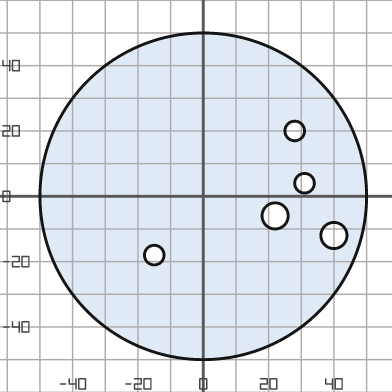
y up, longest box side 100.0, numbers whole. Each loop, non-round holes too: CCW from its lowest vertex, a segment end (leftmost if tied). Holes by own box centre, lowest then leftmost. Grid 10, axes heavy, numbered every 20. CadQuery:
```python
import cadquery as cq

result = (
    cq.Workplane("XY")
    .moveTo(0.0, 0.0)
    .circle(50.0)
    .moveTo(-15.0, -18.0)
    .circle(3.0)
    .moveTo(40.0, -12.0)
    .circle(4.0)
    .moveTo(22.0, -6.0)
    .circle(4.0)
    .moveTo(31.0, 4.0)
    .circle(3.0)
    .moveTo(28.0, 20.0)
    .circle(3.0)
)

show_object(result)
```